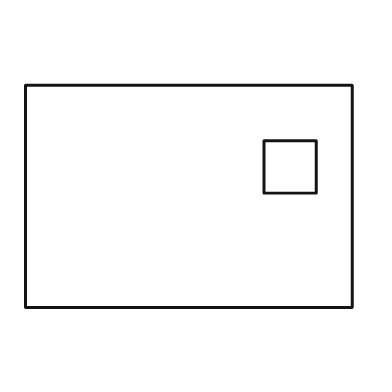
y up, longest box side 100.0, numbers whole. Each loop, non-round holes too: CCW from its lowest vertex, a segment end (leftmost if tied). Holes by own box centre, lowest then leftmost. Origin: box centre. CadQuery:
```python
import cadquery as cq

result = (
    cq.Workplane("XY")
    .moveTo(-50.0, -34.0)
    .lineTo(50.0, -34.0)
    .lineTo(50.0, 34.0)
    .lineTo(-50.0, 34.0)
    .close()
    .moveTo(23.0, 1.0)
    .lineTo(39.0, 1.0)
    .lineTo(39.0, 17.0)
    .lineTo(23.0, 17.0)
    .close()
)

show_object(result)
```